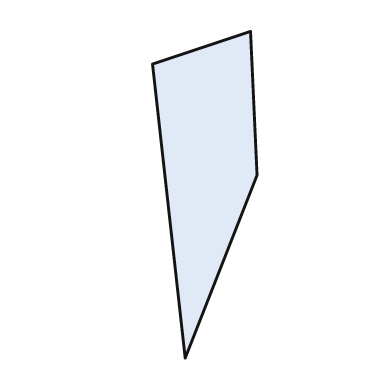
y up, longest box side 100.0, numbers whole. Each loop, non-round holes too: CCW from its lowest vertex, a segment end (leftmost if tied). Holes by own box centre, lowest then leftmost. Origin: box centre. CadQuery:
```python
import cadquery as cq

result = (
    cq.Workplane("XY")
    .moveTo(-6.0, -50.0)
    .lineTo(16.0, 6.0)
    .lineTo(14.0, 50.0)
    .lineTo(-16.0, 40.0)
    .close()
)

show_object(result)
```